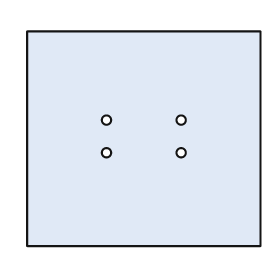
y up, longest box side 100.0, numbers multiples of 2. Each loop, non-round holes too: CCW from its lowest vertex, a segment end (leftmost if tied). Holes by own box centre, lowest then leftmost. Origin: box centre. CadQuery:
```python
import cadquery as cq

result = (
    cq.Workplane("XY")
    .moveTo(-50.0, -46.0)
    .lineTo(50.0, -46.0)
    .lineTo(50.0, 46.0)
    .lineTo(-50.0, 46.0)
    .close()
    .moveTo(-16.0, -6.0)
    .circle(2.0)
    .moveTo(16.0, -6.0)
    .circle(2.0)
    .moveTo(-16.0, 8.0)
    .circle(2.0)
    .moveTo(16.0, 8.0)
    .circle(2.0)
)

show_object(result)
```